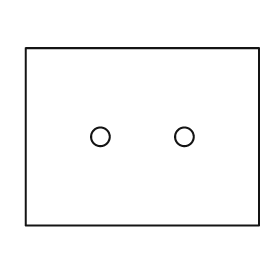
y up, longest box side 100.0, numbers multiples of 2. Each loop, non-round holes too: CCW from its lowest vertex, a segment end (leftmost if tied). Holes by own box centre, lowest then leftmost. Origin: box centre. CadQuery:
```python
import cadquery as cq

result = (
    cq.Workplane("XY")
    .moveTo(-50.0, -38.0)
    .lineTo(50.0, -38.0)
    .lineTo(50.0, 38.0)
    .lineTo(-50.0, 38.0)
    .close()
    .moveTo(-18.0, 0.0)
    .circle(4.0)
    .moveTo(18.0, 0.0)
    .circle(4.0)
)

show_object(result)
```